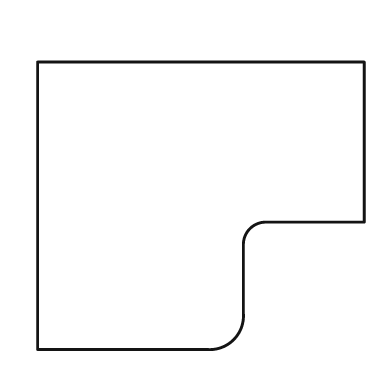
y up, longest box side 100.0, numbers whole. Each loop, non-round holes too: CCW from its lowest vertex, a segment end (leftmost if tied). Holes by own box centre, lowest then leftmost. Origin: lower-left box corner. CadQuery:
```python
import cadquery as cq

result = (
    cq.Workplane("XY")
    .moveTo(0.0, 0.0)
    .lineTo(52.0, 0.0)
    .threePointArc((60.0, 3.0), (63.0, 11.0))
    .lineTo(63.0, 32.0)
    .threePointArc((65.0, 37.0), (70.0, 39.0))
    .lineTo(100.0, 39.0)
    .lineTo(100.0, 88.0)
    .lineTo(0.0, 88.0)
    .close()
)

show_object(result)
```